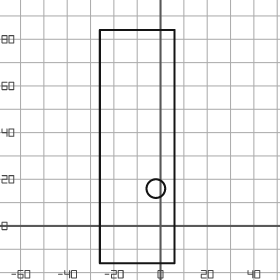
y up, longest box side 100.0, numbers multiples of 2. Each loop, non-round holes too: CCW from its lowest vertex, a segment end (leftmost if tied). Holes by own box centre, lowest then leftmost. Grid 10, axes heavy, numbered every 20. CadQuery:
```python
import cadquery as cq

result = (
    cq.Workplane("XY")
    .moveTo(-26.0, -16.0)
    .lineTo(6.0, -16.0)
    .lineTo(6.0, 84.0)
    .lineTo(-26.0, 84.0)
    .close()
    .moveTo(-2.0, 16.0)
    .circle(4.0)
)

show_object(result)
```